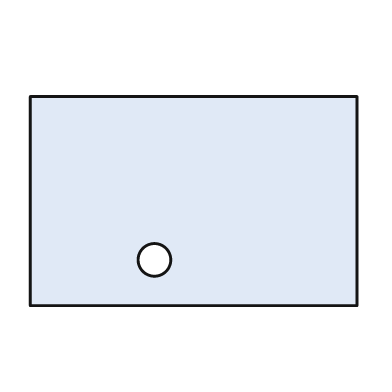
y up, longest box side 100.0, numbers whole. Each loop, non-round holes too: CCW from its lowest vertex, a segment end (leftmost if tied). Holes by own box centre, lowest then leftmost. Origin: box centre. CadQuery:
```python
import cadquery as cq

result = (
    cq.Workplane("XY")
    .moveTo(-50.0, -32.0)
    .lineTo(50.0, -32.0)
    .lineTo(50.0, 32.0)
    .lineTo(-50.0, 32.0)
    .close()
    .moveTo(-12.0, -18.0)
    .circle(5.0)
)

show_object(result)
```